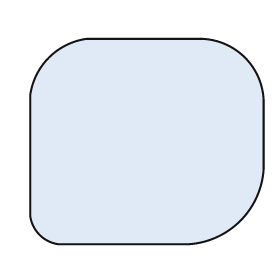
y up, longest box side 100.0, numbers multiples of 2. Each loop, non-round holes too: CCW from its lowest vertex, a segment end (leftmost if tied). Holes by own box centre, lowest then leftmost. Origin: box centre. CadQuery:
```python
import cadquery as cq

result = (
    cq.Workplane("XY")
    .moveTo(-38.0, -44.0)
    .lineTo(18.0, -44.0)
    .threePointArc((40.0, -34.0), (50.0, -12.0))
    .lineTo(50.0, 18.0)
    .threePointArc((42.0, 36.0), (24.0, 44.0))
    .lineTo(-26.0, 44.0)
    .threePointArc((-42.0, 36.0), (-50.0, 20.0))
    .lineTo(-50.0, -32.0)
    .threePointArc((-46.0, -40.0), (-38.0, -44.0))
    .close()
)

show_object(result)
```